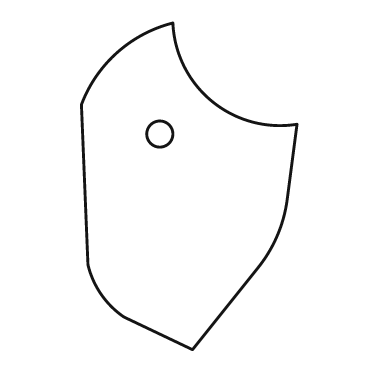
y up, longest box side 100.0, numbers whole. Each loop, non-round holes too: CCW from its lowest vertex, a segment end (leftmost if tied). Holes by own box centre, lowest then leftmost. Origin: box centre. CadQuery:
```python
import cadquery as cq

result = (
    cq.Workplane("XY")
    .moveTo(1.0, -50.0)
    .lineTo(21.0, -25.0)
    .threePointArc((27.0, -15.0), (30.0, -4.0))
    .lineTo(33.0, 19.0)
    .threePointArc((7.0, 26.0), (-5.0, 50.0))
    .threePointArc((-22.0, 41.0), (-33.0, 25.0))
    .lineTo(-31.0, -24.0)
    .threePointArc((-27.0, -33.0), (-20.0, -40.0))
    .close()
    .moveTo(-9.0, 16.0)
    .circle(4.0)
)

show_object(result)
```